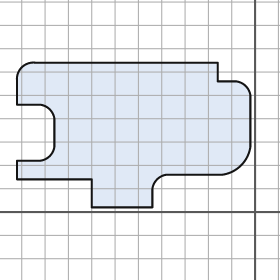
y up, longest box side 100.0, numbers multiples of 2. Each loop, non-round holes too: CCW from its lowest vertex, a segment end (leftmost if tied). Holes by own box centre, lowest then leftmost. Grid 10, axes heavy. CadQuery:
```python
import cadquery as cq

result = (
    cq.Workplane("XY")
    .moveTo(-70.0, 2.0)
    .lineTo(-44.0, 2.0)
    .lineTo(-44.0, 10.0)
    .threePointArc((-42.0, 14.0), (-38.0, 16.0))
    .lineTo(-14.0, 16.0)
    .threePointArc((-6.0, 20.0), (-2.0, 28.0))
    .lineTo(-2.0, 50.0)
    .threePointArc((-4.0, 54.0), (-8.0, 56.0))
    .lineTo(-16.0, 56.0)
    .lineTo(-16.0, 64.0)
    .lineTo(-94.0, 64.0)
    .threePointArc((-100.0, 62.0), (-102.0, 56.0))
    .lineTo(-102.0, 46.0)
    .lineTo(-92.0, 46.0)
    .threePointArc((-88.0, 44.0), (-86.0, 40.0))
    .lineTo(-86.0, 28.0)
    .threePointArc((-88.0, 24.0), (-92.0, 22.0))
    .lineTo(-102.0, 22.0)
    .lineTo(-102.0, 14.0)
    .lineTo(-70.0, 14.0)
    .close()
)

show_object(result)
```